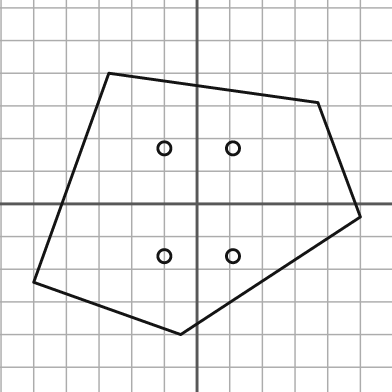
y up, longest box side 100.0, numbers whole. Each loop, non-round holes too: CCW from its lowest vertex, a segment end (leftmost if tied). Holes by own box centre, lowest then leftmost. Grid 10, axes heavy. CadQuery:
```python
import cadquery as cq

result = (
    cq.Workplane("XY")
    .moveTo(-5.0, -40.0)
    .lineTo(50.0, -4.0)
    .lineTo(37.0, 31.0)
    .lineTo(-27.0, 40.0)
    .lineTo(-50.0, -24.0)
    .close()
    .moveTo(-10.0, -16.0)
    .circle(2.0)
    .moveTo(11.0, -16.0)
    .circle(2.0)
    .moveTo(-10.0, 17.0)
    .circle(2.0)
    .moveTo(11.0, 17.0)
    .circle(2.0)
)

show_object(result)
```